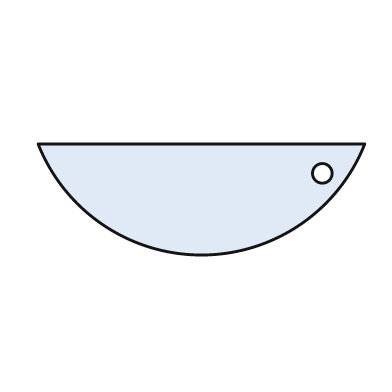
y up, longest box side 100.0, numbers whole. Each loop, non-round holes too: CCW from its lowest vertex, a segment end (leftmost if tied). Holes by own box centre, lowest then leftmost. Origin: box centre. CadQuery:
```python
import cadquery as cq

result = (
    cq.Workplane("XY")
    .moveTo(-50.0, 17.0)
    .threePointArc((0.0, -17.0), (50.0, 17.0))
    .close()
    .moveTo(37.0, 8.0)
    .circle(3.0)
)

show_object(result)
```